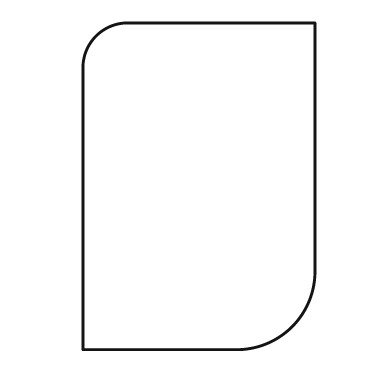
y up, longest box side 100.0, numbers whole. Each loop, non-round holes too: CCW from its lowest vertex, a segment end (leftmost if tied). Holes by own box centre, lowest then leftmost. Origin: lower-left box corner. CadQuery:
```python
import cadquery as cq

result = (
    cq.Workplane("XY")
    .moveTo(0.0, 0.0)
    .lineTo(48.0, 0.0)
    .threePointArc((64.0, 7.0), (71.0, 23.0))
    .lineTo(71.0, 100.0)
    .lineTo(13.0, 100.0)
    .threePointArc((4.0, 96.0), (0.0, 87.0))
    .close()
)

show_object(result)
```